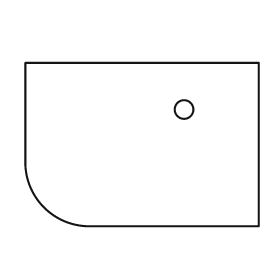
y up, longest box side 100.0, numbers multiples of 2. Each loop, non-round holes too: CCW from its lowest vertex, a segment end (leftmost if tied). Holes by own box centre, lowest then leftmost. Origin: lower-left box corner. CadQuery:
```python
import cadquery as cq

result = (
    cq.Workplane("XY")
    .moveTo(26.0, 0.0)
    .lineTo(100.0, 0.0)
    .lineTo(100.0, 70.0)
    .lineTo(0.0, 70.0)
    .lineTo(0.0, 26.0)
    .threePointArc((8.0, 8.0), (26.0, 0.0))
    .close()
    .moveTo(68.0, 50.0)
    .circle(4.0)
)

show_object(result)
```